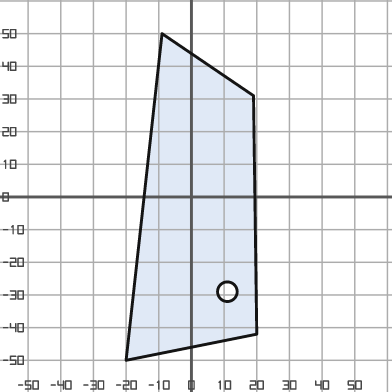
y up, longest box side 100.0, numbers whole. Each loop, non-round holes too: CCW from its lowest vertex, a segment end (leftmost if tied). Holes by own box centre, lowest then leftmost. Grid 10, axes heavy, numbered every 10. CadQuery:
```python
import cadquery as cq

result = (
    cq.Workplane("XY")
    .moveTo(-20.0, -50.0)
    .lineTo(20.0, -42.0)
    .lineTo(19.0, 31.0)
    .lineTo(-9.0, 50.0)
    .close()
    .moveTo(11.0, -29.0)
    .circle(3.0)
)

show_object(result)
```